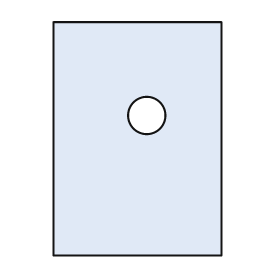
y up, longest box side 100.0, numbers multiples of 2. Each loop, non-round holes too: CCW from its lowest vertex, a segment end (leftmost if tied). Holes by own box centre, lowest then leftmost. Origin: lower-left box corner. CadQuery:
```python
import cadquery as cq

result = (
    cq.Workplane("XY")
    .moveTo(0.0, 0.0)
    .lineTo(72.0, 0.0)
    .lineTo(72.0, 100.0)
    .lineTo(0.0, 100.0)
    .close()
    .moveTo(40.0, 60.0)
    .circle(8.0)
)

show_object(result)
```